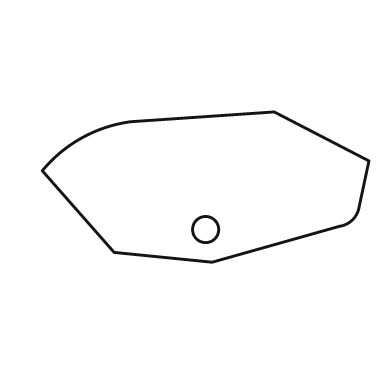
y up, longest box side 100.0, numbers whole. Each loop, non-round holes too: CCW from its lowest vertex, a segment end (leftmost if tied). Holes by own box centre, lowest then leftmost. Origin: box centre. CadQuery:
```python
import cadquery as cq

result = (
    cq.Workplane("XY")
    .moveTo(2.0, -23.0)
    .lineTo(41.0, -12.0)
    .threePointArc((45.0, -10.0), (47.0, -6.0))
    .lineTo(50.0, 8.0)
    .lineTo(21.0, 23.0)
    .lineTo(-23.0, 20.0)
    .threePointArc((-38.0, 15.0), (-50.0, 5.0))
    .lineTo(-28.0, -20.0)
    .close()
    .moveTo(0.0, -13.0)
    .circle(4.0)
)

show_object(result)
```